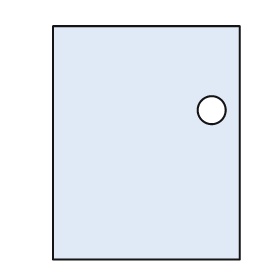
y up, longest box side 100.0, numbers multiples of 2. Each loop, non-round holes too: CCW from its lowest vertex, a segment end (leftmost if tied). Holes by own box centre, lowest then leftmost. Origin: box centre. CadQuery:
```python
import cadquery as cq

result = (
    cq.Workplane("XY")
    .moveTo(-40.0, -50.0)
    .lineTo(40.0, -50.0)
    .lineTo(40.0, 50.0)
    .lineTo(-40.0, 50.0)
    .close()
    .moveTo(28.0, 14.0)
    .circle(6.0)
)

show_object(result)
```